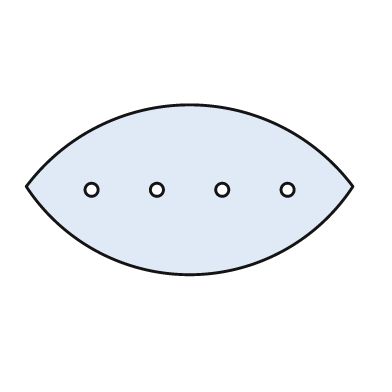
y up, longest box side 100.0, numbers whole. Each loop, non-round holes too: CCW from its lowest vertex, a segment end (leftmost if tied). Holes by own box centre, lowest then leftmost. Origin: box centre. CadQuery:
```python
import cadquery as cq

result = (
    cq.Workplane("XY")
    .moveTo(-50.0, 1.0)
    .threePointArc((0.0, -26.0), (50.0, 1.0))
    .threePointArc((0.0, 26.0), (-50.0, 1.0))
    .close()
    .moveTo(-30.0, 0.0)
    .circle(2.0)
    .moveTo(-10.0, 0.0)
    .circle(2.0)
    .moveTo(10.0, 0.0)
    .circle(2.0)
    .moveTo(30.0, 0.0)
    .circle(2.0)
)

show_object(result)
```